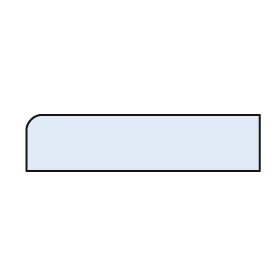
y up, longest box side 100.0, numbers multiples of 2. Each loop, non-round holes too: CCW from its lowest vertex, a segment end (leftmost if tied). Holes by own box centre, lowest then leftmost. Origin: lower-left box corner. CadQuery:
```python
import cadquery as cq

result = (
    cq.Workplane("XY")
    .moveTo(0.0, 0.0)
    .lineTo(100.0, 0.0)
    .lineTo(100.0, 24.0)
    .lineTo(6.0, 24.0)
    .threePointArc((2.0, 22.0), (0.0, 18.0))
    .close()
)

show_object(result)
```